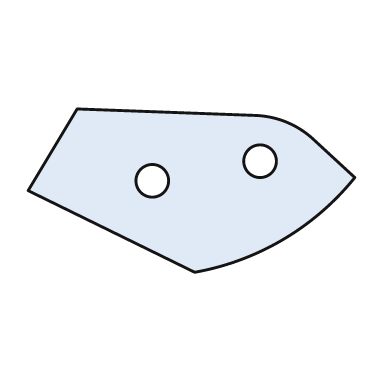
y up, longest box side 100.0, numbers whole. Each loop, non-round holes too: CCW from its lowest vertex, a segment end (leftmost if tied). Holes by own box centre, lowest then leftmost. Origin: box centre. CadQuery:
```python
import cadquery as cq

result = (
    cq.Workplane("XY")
    .moveTo(1.0, -25.0)
    .threePointArc((28.0, -15.0), (50.0, 4.0))
    .lineTo(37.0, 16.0)
    .threePointArc((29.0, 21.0), (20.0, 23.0))
    .lineTo(-35.0, 25.0)
    .lineTo(-50.0, 0.0)
    .close()
    .moveTo(-12.0, 3.0)
    .circle(5.0)
    .moveTo(21.0, 9.0)
    .circle(5.0)
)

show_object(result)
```